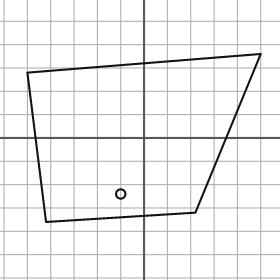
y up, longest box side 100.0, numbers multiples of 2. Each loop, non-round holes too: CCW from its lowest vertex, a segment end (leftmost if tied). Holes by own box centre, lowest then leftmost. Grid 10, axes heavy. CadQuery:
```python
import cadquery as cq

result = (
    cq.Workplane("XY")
    .moveTo(-42.0, -36.0)
    .lineTo(22.0, -32.0)
    .lineTo(50.0, 36.0)
    .lineTo(-50.0, 28.0)
    .close()
    .moveTo(-10.0, -24.0)
    .circle(2.0)
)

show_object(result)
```